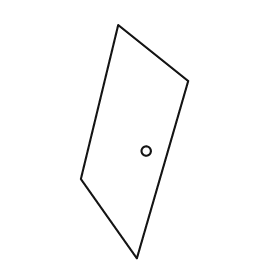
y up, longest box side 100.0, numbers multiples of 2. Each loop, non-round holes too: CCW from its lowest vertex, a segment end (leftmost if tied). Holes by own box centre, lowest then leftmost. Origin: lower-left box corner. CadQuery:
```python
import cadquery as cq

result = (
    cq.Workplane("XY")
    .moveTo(24.0, 0.0)
    .lineTo(46.0, 76.0)
    .lineTo(16.0, 100.0)
    .lineTo(0.0, 34.0)
    .close()
    .moveTo(28.0, 46.0)
    .circle(2.0)
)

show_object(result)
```